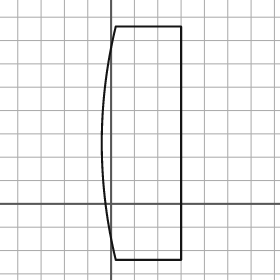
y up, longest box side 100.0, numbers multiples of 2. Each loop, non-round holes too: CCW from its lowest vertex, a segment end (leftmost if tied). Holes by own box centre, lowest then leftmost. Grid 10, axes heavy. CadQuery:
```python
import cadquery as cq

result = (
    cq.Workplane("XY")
    .moveTo(2.0, -24.0)
    .lineTo(30.0, -24.0)
    .lineTo(30.0, 76.0)
    .lineTo(2.0, 76.0)
    .threePointArc((-4.0, 26.0), (2.0, -24.0))
    .close()
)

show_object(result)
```